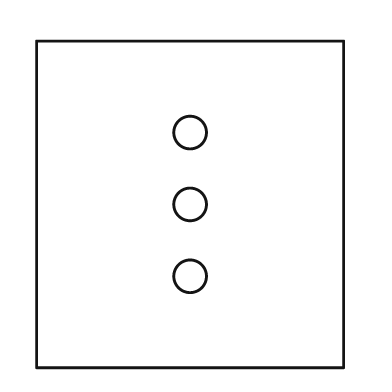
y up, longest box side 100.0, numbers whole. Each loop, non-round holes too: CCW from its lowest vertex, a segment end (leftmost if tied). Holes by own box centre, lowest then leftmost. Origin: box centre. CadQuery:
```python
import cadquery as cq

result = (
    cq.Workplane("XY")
    .moveTo(-47.0, -50.0)
    .lineTo(47.0, -50.0)
    .lineTo(47.0, 50.0)
    .lineTo(-47.0, 50.0)
    .close()
    .moveTo(0.0, -22.0)
    .circle(5.0)
    .moveTo(0.0, 0.0)
    .circle(5.0)
    .moveTo(0.0, 22.0)
    .circle(5.0)
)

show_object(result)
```